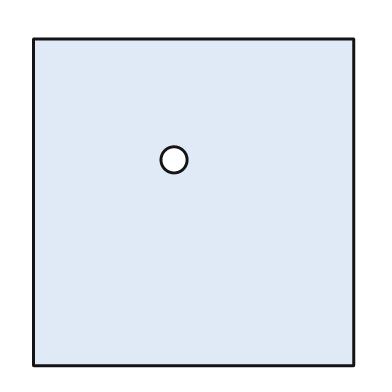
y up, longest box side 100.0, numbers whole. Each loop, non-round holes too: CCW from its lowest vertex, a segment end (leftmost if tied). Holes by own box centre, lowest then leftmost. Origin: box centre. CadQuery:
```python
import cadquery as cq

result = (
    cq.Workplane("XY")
    .moveTo(-49.0, -50.0)
    .lineTo(49.0, -50.0)
    .lineTo(49.0, 50.0)
    .lineTo(-49.0, 50.0)
    .close()
    .moveTo(-6.0, 13.0)
    .circle(4.0)
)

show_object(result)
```